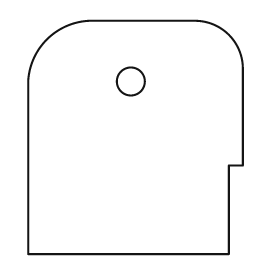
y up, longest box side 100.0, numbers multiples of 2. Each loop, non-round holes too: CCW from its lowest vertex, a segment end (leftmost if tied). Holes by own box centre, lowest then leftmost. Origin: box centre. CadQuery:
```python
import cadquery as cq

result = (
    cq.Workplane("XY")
    .moveTo(-46.0, -50.0)
    .lineTo(40.0, -50.0)
    .lineTo(40.0, -12.0)
    .lineTo(46.0, -12.0)
    .lineTo(46.0, 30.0)
    .threePointArc((40.0, 44.0), (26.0, 50.0))
    .lineTo(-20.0, 50.0)
    .threePointArc((-38.0, 42.0), (-46.0, 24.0))
    .close()
    .moveTo(-2.0, 24.0)
    .circle(6.0)
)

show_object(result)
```